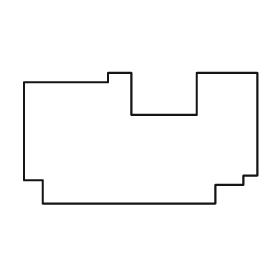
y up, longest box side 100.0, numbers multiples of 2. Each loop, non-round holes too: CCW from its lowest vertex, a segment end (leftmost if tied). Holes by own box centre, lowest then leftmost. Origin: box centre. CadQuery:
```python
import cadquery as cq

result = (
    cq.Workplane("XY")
    .moveTo(-42.0, -28.0)
    .lineTo(32.0, -28.0)
    .lineTo(32.0, -20.0)
    .lineTo(44.0, -20.0)
    .lineTo(44.0, -16.0)
    .lineTo(50.0, -16.0)
    .lineTo(50.0, 28.0)
    .lineTo(24.0, 28.0)
    .lineTo(24.0, 10.0)
    .lineTo(-4.0, 10.0)
    .lineTo(-4.0, 28.0)
    .lineTo(-14.0, 28.0)
    .lineTo(-14.0, 24.0)
    .lineTo(-50.0, 24.0)
    .lineTo(-50.0, -18.0)
    .lineTo(-42.0, -18.0)
    .close()
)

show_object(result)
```